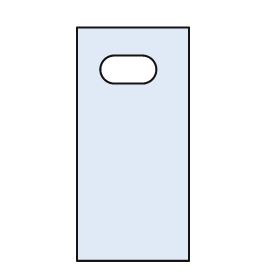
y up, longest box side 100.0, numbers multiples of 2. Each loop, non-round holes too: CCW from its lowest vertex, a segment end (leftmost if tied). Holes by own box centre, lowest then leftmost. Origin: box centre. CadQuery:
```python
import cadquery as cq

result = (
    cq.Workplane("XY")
    .moveTo(-24.0, -50.0)
    .lineTo(24.0, -50.0)
    .lineTo(24.0, 50.0)
    .lineTo(-24.0, 50.0)
    .close()
    .moveTo(-8.0, 26.0)
    .lineTo(4.0, 26.0)
    .threePointArc((10.0, 32.0), (4.0, 38.0))
    .lineTo(-8.0, 38.0)
    .threePointArc((-14.0, 32.0), (-8.0, 26.0))
    .close()
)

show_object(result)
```